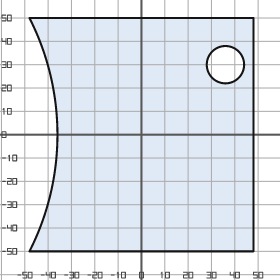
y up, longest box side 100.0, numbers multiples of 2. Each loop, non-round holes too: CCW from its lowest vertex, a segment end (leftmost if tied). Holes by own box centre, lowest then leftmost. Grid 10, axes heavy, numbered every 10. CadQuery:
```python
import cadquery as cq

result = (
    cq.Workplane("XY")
    .moveTo(-48.0, -50.0)
    .lineTo(48.0, -50.0)
    .lineTo(48.0, 50.0)
    .lineTo(-48.0, 50.0)
    .threePointArc((-36.0, 0.0), (-48.0, -50.0))
    .close()
    .moveTo(36.0, 30.0)
    .circle(8.0)
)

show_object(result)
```